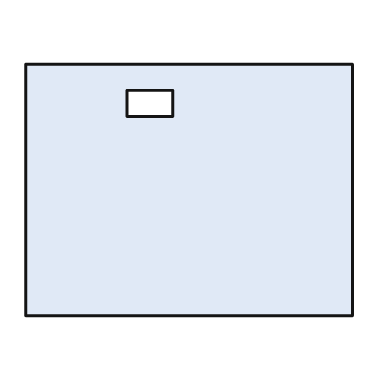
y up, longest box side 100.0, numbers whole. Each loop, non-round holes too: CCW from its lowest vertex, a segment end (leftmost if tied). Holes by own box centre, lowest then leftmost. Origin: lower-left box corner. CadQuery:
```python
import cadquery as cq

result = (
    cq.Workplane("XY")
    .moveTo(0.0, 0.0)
    .lineTo(100.0, 0.0)
    .lineTo(100.0, 77.0)
    .lineTo(0.0, 77.0)
    .close()
    .moveTo(31.0, 61.0)
    .lineTo(45.0, 61.0)
    .lineTo(45.0, 69.0)
    .lineTo(31.0, 69.0)
    .close()
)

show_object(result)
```